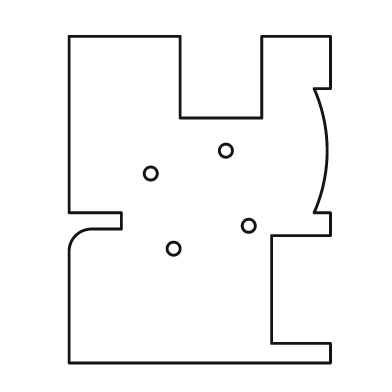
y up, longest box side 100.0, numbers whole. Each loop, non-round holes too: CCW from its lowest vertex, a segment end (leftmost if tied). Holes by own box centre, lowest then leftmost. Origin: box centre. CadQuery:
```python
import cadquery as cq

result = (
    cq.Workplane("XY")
    .moveTo(-40.0, -50.0)
    .lineTo(40.0, -50.0)
    .lineTo(40.0, -44.0)
    .lineTo(22.0, -44.0)
    .lineTo(22.0, -11.0)
    .lineTo(40.0, -11.0)
    .lineTo(40.0, -4.0)
    .lineTo(35.0, -4.0)
    .threePointArc((39.0, 15.0), (35.0, 34.0))
    .lineTo(40.0, 34.0)
    .lineTo(40.0, 50.0)
    .lineTo(19.0, 50.0)
    .lineTo(19.0, 25.0)
    .lineTo(-6.0, 25.0)
    .lineTo(-6.0, 50.0)
    .lineTo(-40.0, 50.0)
    .lineTo(-40.0, -4.0)
    .lineTo(-24.0, -4.0)
    .lineTo(-24.0, -9.0)
    .lineTo(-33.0, -9.0)
    .threePointArc((-38.0, -11.0), (-40.0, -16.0))
    .close()
    .moveTo(-8.0, -15.0)
    .circle(2.0)
    .moveTo(15.0, -8.0)
    .circle(2.0)
    .moveTo(-15.0, 8.0)
    .circle(2.0)
    .moveTo(8.0, 15.0)
    .circle(2.0)
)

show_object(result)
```